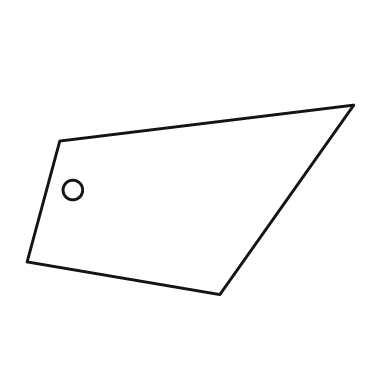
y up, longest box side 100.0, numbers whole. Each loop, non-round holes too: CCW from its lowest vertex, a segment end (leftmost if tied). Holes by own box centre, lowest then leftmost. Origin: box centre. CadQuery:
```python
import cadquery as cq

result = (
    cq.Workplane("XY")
    .moveTo(9.0, -29.0)
    .lineTo(50.0, 29.0)
    .lineTo(-40.0, 18.0)
    .lineTo(-50.0, -19.0)
    .close()
    .moveTo(-36.0, 3.0)
    .circle(3.0)
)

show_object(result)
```